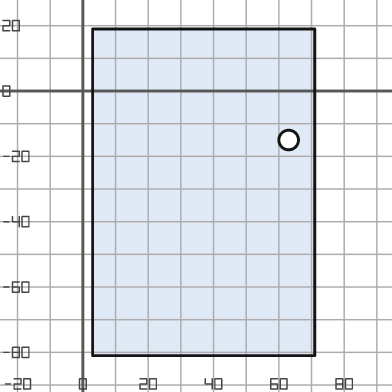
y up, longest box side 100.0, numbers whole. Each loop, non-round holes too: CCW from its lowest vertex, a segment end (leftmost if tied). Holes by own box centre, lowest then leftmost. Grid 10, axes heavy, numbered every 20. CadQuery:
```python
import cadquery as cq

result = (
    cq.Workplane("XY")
    .moveTo(3.0, -81.0)
    .lineTo(71.0, -81.0)
    .lineTo(71.0, 19.0)
    .lineTo(3.0, 19.0)
    .close()
    .moveTo(63.0, -15.0)
    .circle(3.0)
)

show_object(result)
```